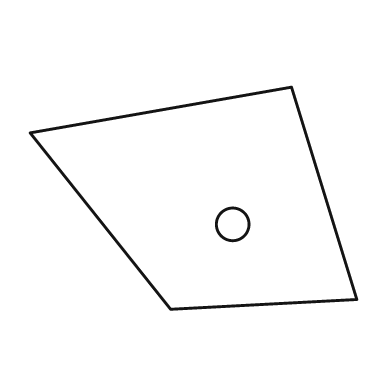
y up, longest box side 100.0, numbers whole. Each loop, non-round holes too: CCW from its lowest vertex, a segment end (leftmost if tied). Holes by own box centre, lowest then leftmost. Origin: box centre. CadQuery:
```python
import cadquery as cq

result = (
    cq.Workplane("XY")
    .moveTo(-7.0, -34.0)
    .lineTo(50.0, -31.0)
    .lineTo(30.0, 34.0)
    .lineTo(-50.0, 20.0)
    .close()
    .moveTo(12.0, -8.0)
    .circle(5.0)
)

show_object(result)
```